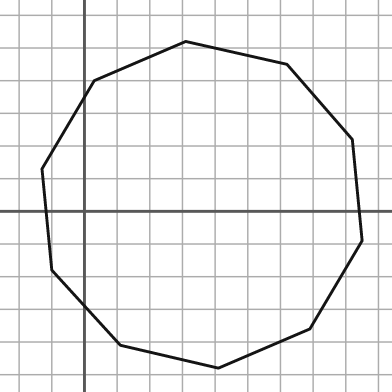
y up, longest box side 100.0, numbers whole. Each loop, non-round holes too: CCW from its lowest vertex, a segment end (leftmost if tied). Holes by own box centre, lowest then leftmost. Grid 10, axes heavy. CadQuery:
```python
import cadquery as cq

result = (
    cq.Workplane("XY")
    .moveTo(41.0, -48.0)
    .lineTo(69.0, -36.0)
    .lineTo(85.0, -9.0)
    .lineTo(82.0, 22.0)
    .lineTo(62.0, 45.0)
    .lineTo(31.0, 52.0)
    .lineTo(3.0, 40.0)
    .lineTo(-13.0, 13.0)
    .lineTo(-10.0, -18.0)
    .lineTo(11.0, -41.0)
    .close()
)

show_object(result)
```